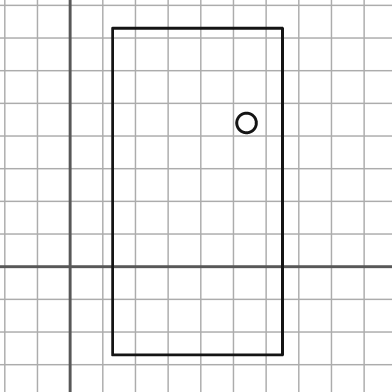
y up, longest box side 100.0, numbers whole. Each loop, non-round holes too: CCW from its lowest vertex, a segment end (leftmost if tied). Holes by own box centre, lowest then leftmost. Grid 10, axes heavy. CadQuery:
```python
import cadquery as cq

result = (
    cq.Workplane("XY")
    .moveTo(13.0, -27.0)
    .lineTo(65.0, -27.0)
    .lineTo(65.0, 73.0)
    .lineTo(13.0, 73.0)
    .close()
    .moveTo(54.0, 44.0)
    .circle(3.0)
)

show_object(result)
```